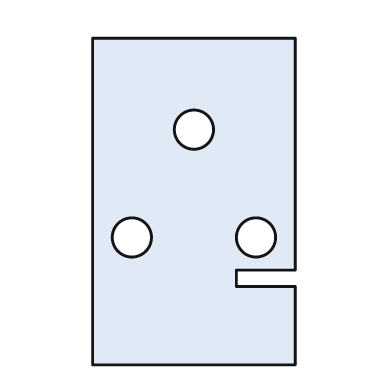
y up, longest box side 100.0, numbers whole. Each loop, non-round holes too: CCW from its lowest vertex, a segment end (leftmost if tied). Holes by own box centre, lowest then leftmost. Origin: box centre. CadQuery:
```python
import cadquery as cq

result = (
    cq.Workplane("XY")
    .moveTo(-31.0, -50.0)
    .lineTo(31.0, -50.0)
    .lineTo(31.0, -26.0)
    .lineTo(13.0, -26.0)
    .lineTo(13.0, -21.0)
    .lineTo(31.0, -21.0)
    .lineTo(31.0, 50.0)
    .lineTo(-31.0, 50.0)
    .close()
    .moveTo(-19.0, -11.0)
    .circle(6.0)
    .moveTo(19.0, -11.0)
    .circle(6.0)
    .moveTo(0.0, 22.0)
    .circle(6.0)
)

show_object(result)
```